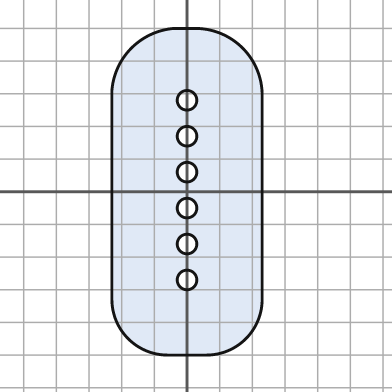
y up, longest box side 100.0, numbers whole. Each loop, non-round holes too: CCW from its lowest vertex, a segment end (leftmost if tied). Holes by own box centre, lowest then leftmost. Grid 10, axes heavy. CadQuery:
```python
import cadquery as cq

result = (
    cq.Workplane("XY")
    .moveTo(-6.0, -50.0)
    .lineTo(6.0, -50.0)
    .threePointArc((18.0, -45.0), (23.0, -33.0))
    .lineTo(23.0, 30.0)
    .threePointArc((17.0, 44.0), (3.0, 50.0))
    .lineTo(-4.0, 50.0)
    .threePointArc((-17.0, 44.0), (-23.0, 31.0))
    .lineTo(-23.0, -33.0)
    .threePointArc((-18.0, -45.0), (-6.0, -50.0))
    .close()
    .moveTo(0.0, -27.0)
    .circle(3.0)
    .moveTo(0.0, -16.0)
    .circle(3.0)
    .moveTo(0.0, -5.0)
    .circle(3.0)
    .moveTo(0.0, 6.0)
    .circle(3.0)
    .moveTo(0.0, 17.0)
    .circle(3.0)
    .moveTo(0.0, 28.0)
    .circle(3.0)
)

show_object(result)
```